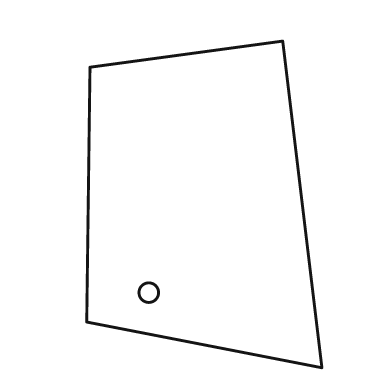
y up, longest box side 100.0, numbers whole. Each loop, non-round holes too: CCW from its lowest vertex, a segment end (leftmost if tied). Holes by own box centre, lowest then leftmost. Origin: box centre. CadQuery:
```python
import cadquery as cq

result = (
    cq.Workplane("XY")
    .moveTo(36.0, -50.0)
    .lineTo(24.0, 50.0)
    .lineTo(-35.0, 42.0)
    .lineTo(-36.0, -36.0)
    .close()
    .moveTo(-17.0, -27.0)
    .circle(3.0)
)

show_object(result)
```